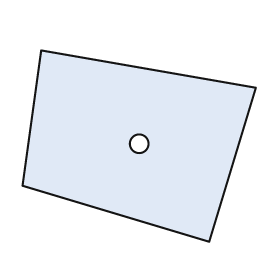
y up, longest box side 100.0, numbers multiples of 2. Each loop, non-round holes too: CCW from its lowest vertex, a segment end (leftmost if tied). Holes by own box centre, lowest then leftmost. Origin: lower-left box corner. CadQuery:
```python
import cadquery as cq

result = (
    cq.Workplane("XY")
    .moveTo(80.0, 0.0)
    .lineTo(100.0, 66.0)
    .lineTo(8.0, 82.0)
    .lineTo(0.0, 24.0)
    .close()
    .moveTo(50.0, 42.0)
    .circle(4.0)
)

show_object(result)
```